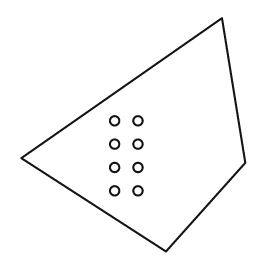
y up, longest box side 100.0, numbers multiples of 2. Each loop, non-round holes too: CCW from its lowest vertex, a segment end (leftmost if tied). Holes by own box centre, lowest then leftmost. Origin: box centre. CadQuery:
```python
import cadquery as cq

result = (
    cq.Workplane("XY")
    .moveTo(14.0, -50.0)
    .lineTo(48.0, -12.0)
    .lineTo(38.0, 50.0)
    .lineTo(-48.0, -10.0)
    .close()
    .moveTo(-8.0, -24.0)
    .circle(2.0)
    .moveTo(2.0, -24.0)
    .circle(2.0)
    .moveTo(-8.0, -14.0)
    .circle(2.0)
    .moveTo(2.0, -14.0)
    .circle(2.0)
    .moveTo(-8.0, -4.0)
    .circle(2.0)
    .moveTo(2.0, -4.0)
    .circle(2.0)
    .moveTo(-8.0, 6.0)
    .circle(2.0)
    .moveTo(2.0, 6.0)
    .circle(2.0)
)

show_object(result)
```